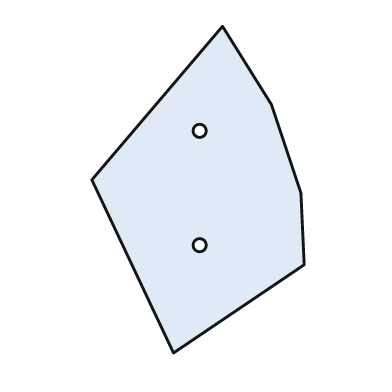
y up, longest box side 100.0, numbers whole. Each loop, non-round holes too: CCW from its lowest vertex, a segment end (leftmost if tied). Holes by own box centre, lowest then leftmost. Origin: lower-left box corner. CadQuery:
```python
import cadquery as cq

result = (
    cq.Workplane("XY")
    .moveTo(25.0, 0.0)
    .lineTo(65.0, 27.0)
    .lineTo(64.0, 49.0)
    .lineTo(55.0, 76.0)
    .lineTo(40.0, 100.0)
    .lineTo(0.0, 53.0)
    .close()
    .moveTo(33.0, 33.0)
    .circle(2.0)
    .moveTo(33.0, 68.0)
    .circle(2.0)
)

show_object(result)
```